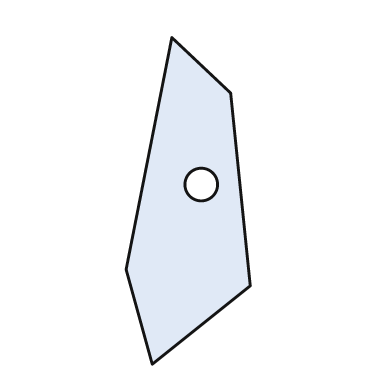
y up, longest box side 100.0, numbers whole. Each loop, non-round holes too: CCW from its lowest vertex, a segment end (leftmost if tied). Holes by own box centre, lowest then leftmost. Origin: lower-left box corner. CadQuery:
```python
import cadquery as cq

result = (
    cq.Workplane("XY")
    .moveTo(8.0, 0.0)
    .lineTo(38.0, 24.0)
    .lineTo(32.0, 83.0)
    .lineTo(14.0, 100.0)
    .lineTo(0.0, 29.0)
    .close()
    .moveTo(23.0, 55.0)
    .circle(5.0)
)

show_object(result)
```